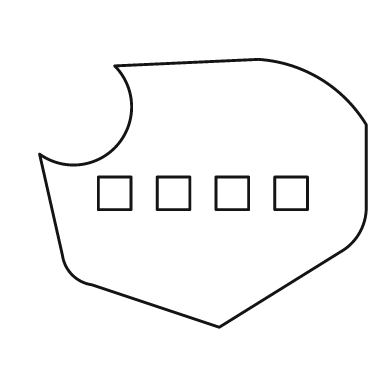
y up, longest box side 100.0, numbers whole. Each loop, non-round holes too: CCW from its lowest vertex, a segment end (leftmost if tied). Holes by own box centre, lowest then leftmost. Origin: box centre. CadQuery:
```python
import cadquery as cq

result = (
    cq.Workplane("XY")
    .moveTo(5.0, -41.0)
    .lineTo(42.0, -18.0)
    .threePointArc((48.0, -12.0), (50.0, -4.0))
    .lineTo(50.0, 21.0)
    .threePointArc((36.0, 35.0), (17.0, 41.0))
    .lineTo(-27.0, 39.0)
    .threePointArc((-26.0, 15.0), (-50.0, 12.0))
    .lineTo(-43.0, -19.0)
    .threePointArc((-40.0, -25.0), (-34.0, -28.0))
    .close()
    .moveTo(-32.0, -5.0)
    .lineTo(-22.0, -5.0)
    .lineTo(-22.0, 5.0)
    .lineTo(-32.0, 5.0)
    .close()
    .moveTo(-14.0, -5.0)
    .lineTo(-4.0, -5.0)
    .lineTo(-4.0, 5.0)
    .lineTo(-14.0, 5.0)
    .close()
    .moveTo(4.0, -5.0)
    .lineTo(14.0, -5.0)
    .lineTo(14.0, 5.0)
    .lineTo(4.0, 5.0)
    .close()
    .moveTo(22.0, -5.0)
    .lineTo(32.0, -5.0)
    .lineTo(32.0, 5.0)
    .lineTo(22.0, 5.0)
    .close()
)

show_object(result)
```